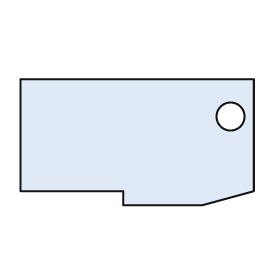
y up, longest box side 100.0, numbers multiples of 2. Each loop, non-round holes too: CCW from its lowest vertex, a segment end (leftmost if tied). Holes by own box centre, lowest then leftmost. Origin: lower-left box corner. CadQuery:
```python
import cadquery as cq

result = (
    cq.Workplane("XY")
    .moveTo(44.0, 0.0)
    .lineTo(78.0, 0.0)
    .lineTo(100.0, 6.0)
    .lineTo(100.0, 54.0)
    .lineTo(0.0, 54.0)
    .lineTo(0.0, 6.0)
    .lineTo(44.0, 6.0)
    .close()
    .moveTo(90.0, 38.0)
    .circle(6.0)
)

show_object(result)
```